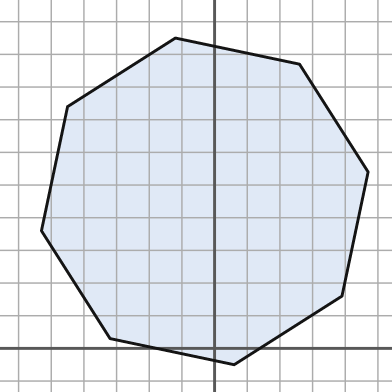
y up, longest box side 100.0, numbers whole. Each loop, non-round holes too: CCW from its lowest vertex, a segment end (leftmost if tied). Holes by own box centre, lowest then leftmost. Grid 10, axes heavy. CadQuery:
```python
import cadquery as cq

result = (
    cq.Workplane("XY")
    .moveTo(6.0, -5.0)
    .lineTo(39.0, 16.0)
    .lineTo(47.0, 54.0)
    .lineTo(26.0, 87.0)
    .lineTo(-12.0, 95.0)
    .lineTo(-45.0, 74.0)
    .lineTo(-53.0, 36.0)
    .lineTo(-32.0, 3.0)
    .close()
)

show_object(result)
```